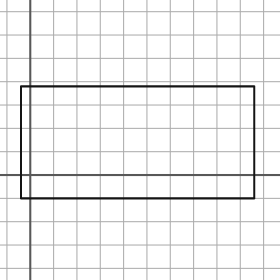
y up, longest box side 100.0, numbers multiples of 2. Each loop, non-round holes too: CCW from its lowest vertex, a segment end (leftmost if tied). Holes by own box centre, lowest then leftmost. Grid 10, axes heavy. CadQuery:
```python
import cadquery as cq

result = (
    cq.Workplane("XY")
    .moveTo(-4.0, -10.0)
    .lineTo(96.0, -10.0)
    .lineTo(96.0, 38.0)
    .lineTo(-4.0, 38.0)
    .close()
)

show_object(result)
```